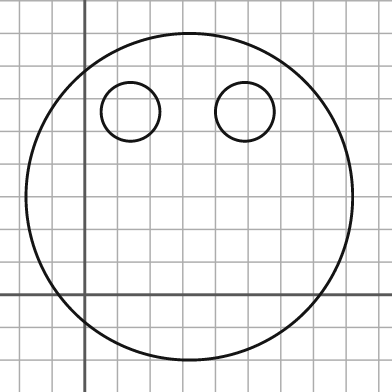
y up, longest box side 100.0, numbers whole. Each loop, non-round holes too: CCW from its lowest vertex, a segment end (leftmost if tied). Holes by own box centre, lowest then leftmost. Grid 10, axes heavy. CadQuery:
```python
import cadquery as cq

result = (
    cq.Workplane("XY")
    .moveTo(32.0, 30.0)
    .circle(50.0)
    .moveTo(14.0, 56.0)
    .circle(9.0)
    .moveTo(49.0, 56.0)
    .circle(9.0)
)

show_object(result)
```